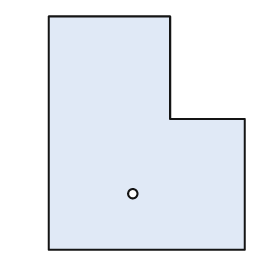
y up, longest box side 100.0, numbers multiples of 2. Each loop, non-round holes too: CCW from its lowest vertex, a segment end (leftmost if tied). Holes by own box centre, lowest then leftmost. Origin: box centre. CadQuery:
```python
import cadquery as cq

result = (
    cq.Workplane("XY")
    .moveTo(-42.0, -50.0)
    .lineTo(42.0, -50.0)
    .lineTo(42.0, 6.0)
    .lineTo(10.0, 6.0)
    .lineTo(10.0, 50.0)
    .lineTo(-42.0, 50.0)
    .close()
    .moveTo(-6.0, -26.0)
    .circle(2.0)
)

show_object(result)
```